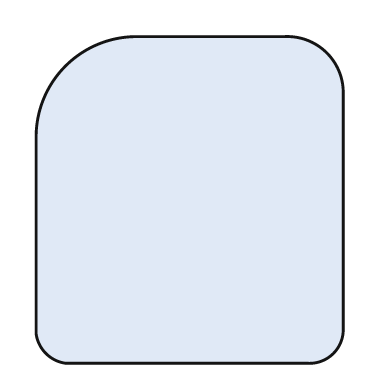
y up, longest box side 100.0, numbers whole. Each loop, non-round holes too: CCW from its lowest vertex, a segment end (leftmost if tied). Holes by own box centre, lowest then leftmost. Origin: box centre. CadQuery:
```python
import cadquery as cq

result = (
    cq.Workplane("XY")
    .moveTo(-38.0, -50.0)
    .lineTo(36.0, -50.0)
    .threePointArc((44.0, -47.0), (47.0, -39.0))
    .lineTo(47.0, 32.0)
    .threePointArc((42.0, 45.0), (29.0, 50.0))
    .lineTo(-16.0, 50.0)
    .threePointArc((-38.0, 41.0), (-47.0, 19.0))
    .lineTo(-47.0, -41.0)
    .threePointArc((-44.0, -47.0), (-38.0, -50.0))
    .close()
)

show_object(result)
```